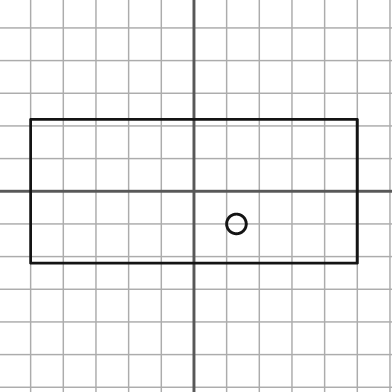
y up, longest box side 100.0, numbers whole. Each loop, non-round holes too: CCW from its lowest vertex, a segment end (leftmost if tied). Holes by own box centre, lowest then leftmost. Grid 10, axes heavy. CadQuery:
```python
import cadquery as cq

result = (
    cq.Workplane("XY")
    .moveTo(-50.0, -22.0)
    .lineTo(50.0, -22.0)
    .lineTo(50.0, 22.0)
    .lineTo(-50.0, 22.0)
    .close()
    .moveTo(13.0, -10.0)
    .circle(3.0)
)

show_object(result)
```